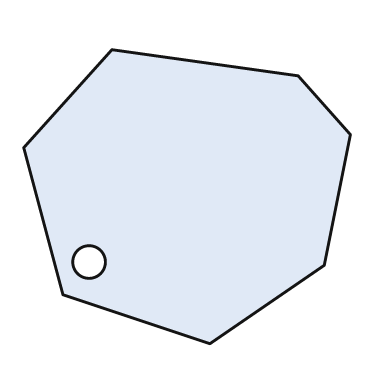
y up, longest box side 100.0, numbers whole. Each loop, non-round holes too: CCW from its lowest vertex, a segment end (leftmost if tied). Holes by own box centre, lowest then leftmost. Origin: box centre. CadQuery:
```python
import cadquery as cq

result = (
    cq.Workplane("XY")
    .moveTo(7.0, -45.0)
    .lineTo(42.0, -21.0)
    .lineTo(50.0, 19.0)
    .lineTo(34.0, 37.0)
    .lineTo(-23.0, 45.0)
    .lineTo(-50.0, 15.0)
    .lineTo(-38.0, -30.0)
    .close()
    .moveTo(-30.0, -20.0)
    .circle(5.0)
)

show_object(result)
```